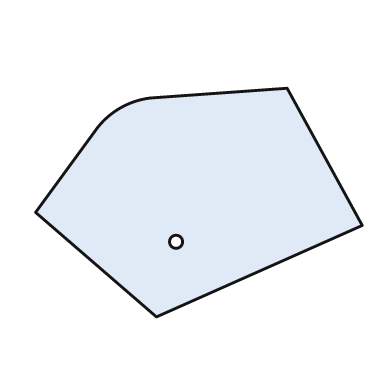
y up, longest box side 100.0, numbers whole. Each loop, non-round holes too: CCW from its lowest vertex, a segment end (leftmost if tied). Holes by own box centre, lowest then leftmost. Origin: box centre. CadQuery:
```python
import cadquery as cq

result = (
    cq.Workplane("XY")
    .moveTo(-13.0, -35.0)
    .lineTo(50.0, -7.0)
    .lineTo(27.0, 35.0)
    .lineTo(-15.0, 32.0)
    .threePointArc((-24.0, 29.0), (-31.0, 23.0))
    .lineTo(-50.0, -3.0)
    .close()
    .moveTo(-7.0, -12.0)
    .circle(2.0)
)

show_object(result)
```